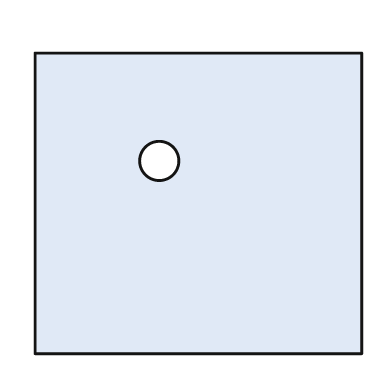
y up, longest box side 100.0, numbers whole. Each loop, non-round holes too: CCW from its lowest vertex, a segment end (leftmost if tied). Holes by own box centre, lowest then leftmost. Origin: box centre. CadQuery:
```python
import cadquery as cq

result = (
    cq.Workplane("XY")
    .moveTo(-50.0, -46.0)
    .lineTo(50.0, -46.0)
    .lineTo(50.0, 46.0)
    .lineTo(-50.0, 46.0)
    .close()
    .moveTo(-12.0, 13.0)
    .circle(6.0)
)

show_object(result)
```